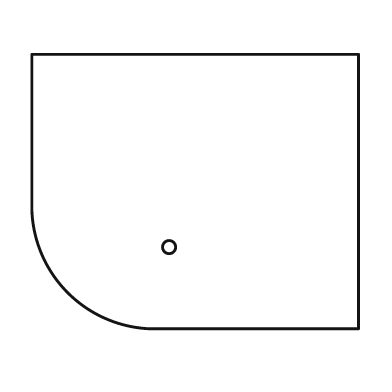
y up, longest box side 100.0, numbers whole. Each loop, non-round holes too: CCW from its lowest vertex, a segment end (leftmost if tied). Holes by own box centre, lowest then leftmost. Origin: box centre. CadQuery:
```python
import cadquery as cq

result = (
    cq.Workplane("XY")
    .moveTo(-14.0, -42.0)
    .lineTo(50.0, -42.0)
    .lineTo(50.0, 42.0)
    .lineTo(-50.0, 42.0)
    .lineTo(-50.0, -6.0)
    .threePointArc((-39.0, -31.0), (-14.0, -42.0))
    .close()
    .moveTo(-8.0, -17.0)
    .circle(2.0)
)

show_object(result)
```